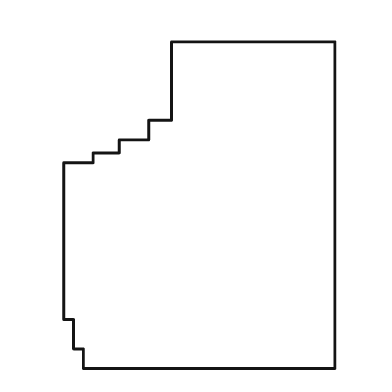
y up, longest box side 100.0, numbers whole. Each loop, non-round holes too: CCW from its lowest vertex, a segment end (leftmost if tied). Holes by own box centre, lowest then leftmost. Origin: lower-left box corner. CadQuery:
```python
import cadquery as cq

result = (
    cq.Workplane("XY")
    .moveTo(6.0, 0.0)
    .lineTo(83.0, 0.0)
    .lineTo(83.0, 100.0)
    .lineTo(33.0, 100.0)
    .lineTo(33.0, 76.0)
    .lineTo(26.0, 76.0)
    .lineTo(26.0, 70.0)
    .lineTo(17.0, 70.0)
    .lineTo(17.0, 66.0)
    .lineTo(9.0, 66.0)
    .lineTo(9.0, 63.0)
    .lineTo(0.0, 63.0)
    .lineTo(0.0, 15.0)
    .lineTo(3.0, 15.0)
    .lineTo(3.0, 6.0)
    .lineTo(6.0, 6.0)
    .close()
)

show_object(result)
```